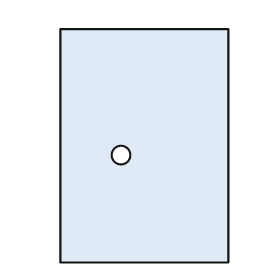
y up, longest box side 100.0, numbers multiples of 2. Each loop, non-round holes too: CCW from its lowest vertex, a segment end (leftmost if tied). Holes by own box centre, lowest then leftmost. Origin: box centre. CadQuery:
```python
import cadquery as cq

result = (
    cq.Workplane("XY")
    .moveTo(-36.0, -50.0)
    .lineTo(36.0, -50.0)
    .lineTo(36.0, 50.0)
    .lineTo(-36.0, 50.0)
    .close()
    .moveTo(-10.0, -4.0)
    .circle(4.0)
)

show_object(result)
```